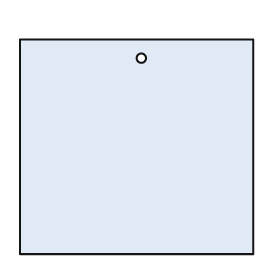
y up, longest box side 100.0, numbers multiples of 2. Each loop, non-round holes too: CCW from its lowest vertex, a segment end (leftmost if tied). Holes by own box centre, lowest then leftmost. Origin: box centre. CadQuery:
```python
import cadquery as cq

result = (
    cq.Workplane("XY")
    .moveTo(-50.0, -46.0)
    .lineTo(50.0, -46.0)
    .lineTo(50.0, 46.0)
    .lineTo(-50.0, 46.0)
    .close()
    .moveTo(2.0, 38.0)
    .circle(2.0)
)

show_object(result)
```